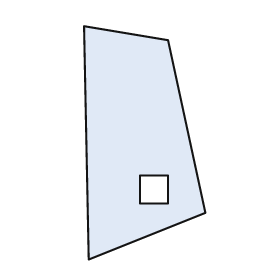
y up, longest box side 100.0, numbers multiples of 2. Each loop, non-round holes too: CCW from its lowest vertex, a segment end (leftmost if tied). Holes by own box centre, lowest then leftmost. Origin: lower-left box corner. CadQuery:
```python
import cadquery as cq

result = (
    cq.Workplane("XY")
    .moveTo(2.0, 0.0)
    .lineTo(52.0, 20.0)
    .lineTo(36.0, 94.0)
    .lineTo(0.0, 100.0)
    .close()
    .moveTo(24.0, 24.0)
    .lineTo(36.0, 24.0)
    .lineTo(36.0, 36.0)
    .lineTo(24.0, 36.0)
    .close()
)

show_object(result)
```